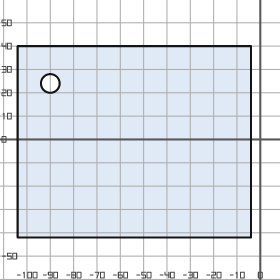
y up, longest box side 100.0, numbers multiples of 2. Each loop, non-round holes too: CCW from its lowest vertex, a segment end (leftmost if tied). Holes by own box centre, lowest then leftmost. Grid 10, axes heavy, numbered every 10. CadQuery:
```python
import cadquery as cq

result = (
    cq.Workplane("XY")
    .moveTo(-104.0, -42.0)
    .lineTo(-4.0, -42.0)
    .lineTo(-4.0, 40.0)
    .lineTo(-104.0, 40.0)
    .close()
    .moveTo(-90.0, 24.0)
    .circle(4.0)
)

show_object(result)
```